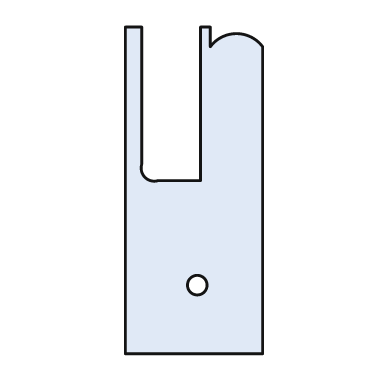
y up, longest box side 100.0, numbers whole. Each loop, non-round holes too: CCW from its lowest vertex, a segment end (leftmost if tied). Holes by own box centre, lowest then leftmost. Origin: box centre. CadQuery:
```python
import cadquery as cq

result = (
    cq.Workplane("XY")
    .moveTo(-21.0, -50.0)
    .lineTo(21.0, -50.0)
    .lineTo(21.0, 44.0)
    .threePointArc((13.0, 48.0), (5.0, 44.0))
    .lineTo(5.0, 50.0)
    .lineTo(2.0, 50.0)
    .lineTo(2.0, 3.0)
    .lineTo(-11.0, 3.0)
    .threePointArc((-15.0, 4.0), (-16.0, 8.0))
    .lineTo(-16.0, 50.0)
    .lineTo(-21.0, 50.0)
    .close()
    .moveTo(1.0, -29.0)
    .circle(3.0)
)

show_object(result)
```